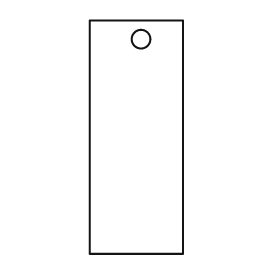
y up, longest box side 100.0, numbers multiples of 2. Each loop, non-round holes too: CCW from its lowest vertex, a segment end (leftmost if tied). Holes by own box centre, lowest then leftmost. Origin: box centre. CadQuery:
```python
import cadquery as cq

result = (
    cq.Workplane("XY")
    .moveTo(-20.0, -50.0)
    .lineTo(20.0, -50.0)
    .lineTo(20.0, 50.0)
    .lineTo(-20.0, 50.0)
    .close()
    .moveTo(2.0, 42.0)
    .circle(4.0)
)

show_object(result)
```